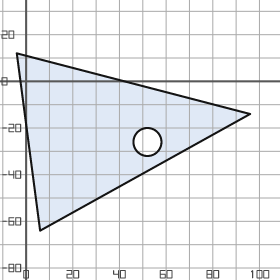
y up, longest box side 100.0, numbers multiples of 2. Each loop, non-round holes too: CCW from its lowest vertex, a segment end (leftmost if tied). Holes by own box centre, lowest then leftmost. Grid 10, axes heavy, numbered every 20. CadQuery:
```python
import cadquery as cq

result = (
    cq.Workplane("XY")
    .moveTo(6.0, -64.0)
    .lineTo(96.0, -14.0)
    .lineTo(-4.0, 12.0)
    .close()
    .moveTo(52.0, -26.0)
    .circle(6.0)
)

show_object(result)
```